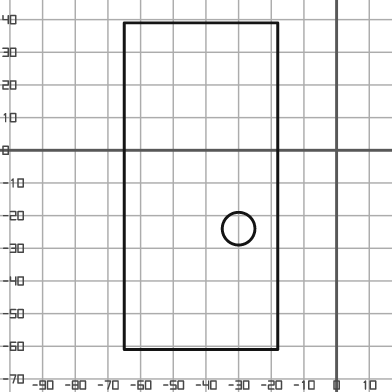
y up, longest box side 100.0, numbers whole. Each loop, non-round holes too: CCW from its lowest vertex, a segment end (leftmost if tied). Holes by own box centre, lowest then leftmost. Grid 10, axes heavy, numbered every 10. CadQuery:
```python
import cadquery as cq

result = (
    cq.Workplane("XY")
    .moveTo(-65.0, -61.0)
    .lineTo(-18.0, -61.0)
    .lineTo(-18.0, 39.0)
    .lineTo(-65.0, 39.0)
    .close()
    .moveTo(-30.0, -24.0)
    .circle(5.0)
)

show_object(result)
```